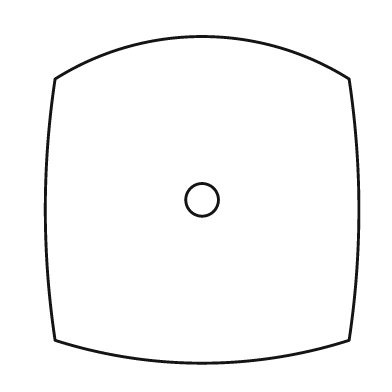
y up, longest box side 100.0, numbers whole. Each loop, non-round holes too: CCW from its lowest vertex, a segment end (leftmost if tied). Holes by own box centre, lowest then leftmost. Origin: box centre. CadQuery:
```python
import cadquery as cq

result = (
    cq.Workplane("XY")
    .moveTo(-45.0, -43.0)
    .threePointArc((0.0, -50.0), (45.0, -43.0))
    .threePointArc((48.0, -3.0), (45.0, 37.0))
    .threePointArc((0.0, 50.0), (-45.0, 37.0))
    .threePointArc((-48.0, -3.0), (-45.0, -43.0))
    .close()
    .moveTo(0.0, 0.0)
    .circle(5.0)
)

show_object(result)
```